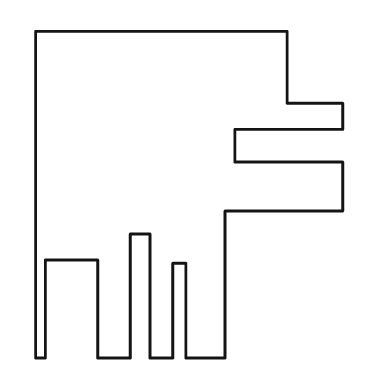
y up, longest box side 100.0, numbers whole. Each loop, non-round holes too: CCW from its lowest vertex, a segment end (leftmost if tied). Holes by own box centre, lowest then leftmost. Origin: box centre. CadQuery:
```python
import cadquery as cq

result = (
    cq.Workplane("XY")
    .moveTo(-47.0, -50.0)
    .lineTo(-44.0, -50.0)
    .lineTo(-44.0, -20.0)
    .lineTo(-28.0, -20.0)
    .lineTo(-28.0, -50.0)
    .lineTo(-18.0, -50.0)
    .lineTo(-18.0, -12.0)
    .lineTo(-12.0, -12.0)
    .lineTo(-12.0, -50.0)
    .lineTo(-5.0, -50.0)
    .lineTo(-5.0, -21.0)
    .lineTo(-1.0, -21.0)
    .lineTo(-1.0, -50.0)
    .lineTo(11.0, -50.0)
    .lineTo(11.0, -5.0)
    .lineTo(47.0, -5.0)
    .lineTo(47.0, 10.0)
    .lineTo(14.0, 10.0)
    .lineTo(14.0, 20.0)
    .lineTo(47.0, 20.0)
    .lineTo(47.0, 28.0)
    .lineTo(30.0, 28.0)
    .lineTo(30.0, 50.0)
    .lineTo(-47.0, 50.0)
    .close()
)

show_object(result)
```